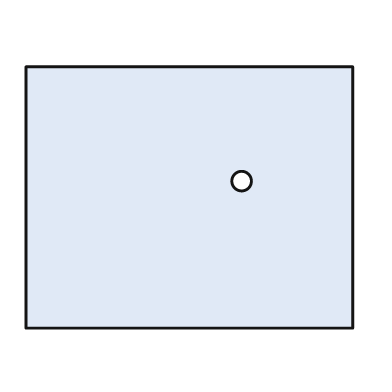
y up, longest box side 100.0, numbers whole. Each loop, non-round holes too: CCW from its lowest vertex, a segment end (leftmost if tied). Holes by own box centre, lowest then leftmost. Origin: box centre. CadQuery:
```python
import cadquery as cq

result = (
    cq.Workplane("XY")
    .moveTo(-50.0, -40.0)
    .lineTo(50.0, -40.0)
    .lineTo(50.0, 40.0)
    .lineTo(-50.0, 40.0)
    .close()
    .moveTo(16.0, 5.0)
    .circle(3.0)
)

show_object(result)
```